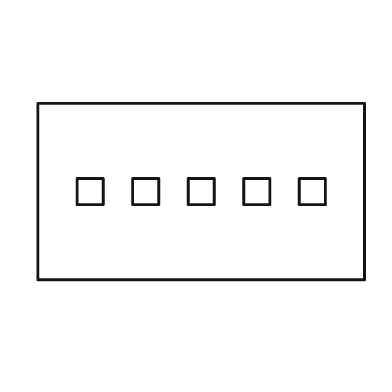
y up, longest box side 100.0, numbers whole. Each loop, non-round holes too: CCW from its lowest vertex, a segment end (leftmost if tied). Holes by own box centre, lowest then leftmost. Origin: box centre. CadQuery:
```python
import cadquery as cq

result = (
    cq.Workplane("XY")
    .moveTo(-50.0, -27.0)
    .lineTo(50.0, -27.0)
    .lineTo(50.0, 27.0)
    .lineTo(-50.0, 27.0)
    .close()
    .moveTo(-38.0, -4.0)
    .lineTo(-30.0, -4.0)
    .lineTo(-30.0, 4.0)
    .lineTo(-38.0, 4.0)
    .close()
    .moveTo(-21.0, -4.0)
    .lineTo(-13.0, -4.0)
    .lineTo(-13.0, 4.0)
    .lineTo(-21.0, 4.0)
    .close()
    .moveTo(-4.0, -4.0)
    .lineTo(4.0, -4.0)
    .lineTo(4.0, 4.0)
    .lineTo(-4.0, 4.0)
    .close()
    .moveTo(13.0, -4.0)
    .lineTo(21.0, -4.0)
    .lineTo(21.0, 4.0)
    .lineTo(13.0, 4.0)
    .close()
    .moveTo(30.0, -4.0)
    .lineTo(38.0, -4.0)
    .lineTo(38.0, 4.0)
    .lineTo(30.0, 4.0)
    .close()
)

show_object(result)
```